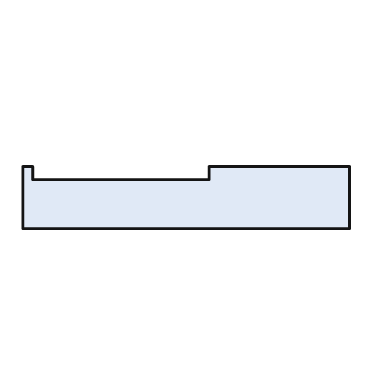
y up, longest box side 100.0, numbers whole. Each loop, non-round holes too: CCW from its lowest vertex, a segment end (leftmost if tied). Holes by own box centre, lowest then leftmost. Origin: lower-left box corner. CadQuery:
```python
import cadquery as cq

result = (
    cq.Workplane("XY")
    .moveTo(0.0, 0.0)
    .lineTo(100.0, 0.0)
    .lineTo(100.0, 19.0)
    .lineTo(57.0, 19.0)
    .lineTo(57.0, 15.0)
    .lineTo(3.0, 15.0)
    .lineTo(3.0, 19.0)
    .lineTo(0.0, 19.0)
    .close()
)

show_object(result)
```